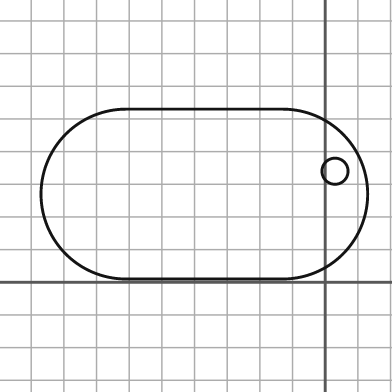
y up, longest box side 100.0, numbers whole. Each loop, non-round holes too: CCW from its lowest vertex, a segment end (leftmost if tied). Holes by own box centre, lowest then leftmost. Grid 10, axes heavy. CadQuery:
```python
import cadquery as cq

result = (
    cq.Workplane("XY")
    .moveTo(-61.0, 1.0)
    .lineTo(-13.0, 1.0)
    .threePointArc((13.0, 27.0), (-13.0, 53.0))
    .lineTo(-61.0, 53.0)
    .threePointArc((-87.0, 27.0), (-61.0, 1.0))
    .close()
    .moveTo(3.0, 34.0)
    .circle(4.0)
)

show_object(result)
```